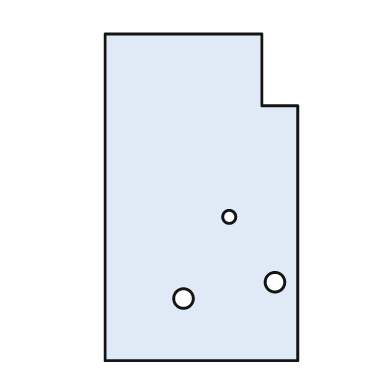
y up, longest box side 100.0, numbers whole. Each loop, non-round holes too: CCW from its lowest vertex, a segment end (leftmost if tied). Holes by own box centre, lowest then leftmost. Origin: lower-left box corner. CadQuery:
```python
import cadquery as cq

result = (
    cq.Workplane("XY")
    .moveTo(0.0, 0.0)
    .lineTo(59.0, 0.0)
    .lineTo(59.0, 78.0)
    .lineTo(48.0, 78.0)
    .lineTo(48.0, 100.0)
    .lineTo(0.0, 100.0)
    .close()
    .moveTo(24.0, 19.0)
    .circle(3.0)
    .moveTo(52.0, 24.0)
    .circle(3.0)
    .moveTo(38.0, 44.0)
    .circle(2.0)
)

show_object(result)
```